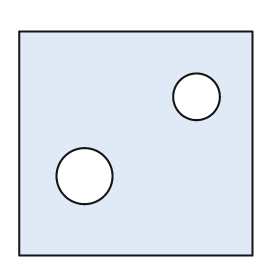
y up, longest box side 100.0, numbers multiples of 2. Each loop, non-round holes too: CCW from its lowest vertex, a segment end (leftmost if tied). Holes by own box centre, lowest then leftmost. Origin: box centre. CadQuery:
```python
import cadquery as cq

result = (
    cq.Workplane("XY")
    .moveTo(-50.0, -48.0)
    .lineTo(50.0, -48.0)
    .lineTo(50.0, 48.0)
    .lineTo(-50.0, 48.0)
    .close()
    .moveTo(-22.0, -14.0)
    .circle(12.0)
    .moveTo(26.0, 20.0)
    .circle(10.0)
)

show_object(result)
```